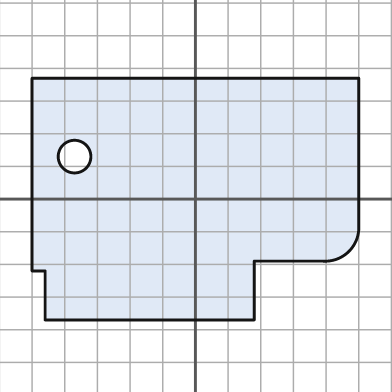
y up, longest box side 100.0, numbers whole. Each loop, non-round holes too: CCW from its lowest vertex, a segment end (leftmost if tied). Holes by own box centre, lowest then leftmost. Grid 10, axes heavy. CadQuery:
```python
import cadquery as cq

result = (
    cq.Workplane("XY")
    .moveTo(-46.0, -37.0)
    .lineTo(18.0, -37.0)
    .lineTo(18.0, -19.0)
    .lineTo(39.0, -19.0)
    .threePointArc((47.0, -16.0), (50.0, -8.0))
    .lineTo(50.0, 37.0)
    .lineTo(-50.0, 37.0)
    .lineTo(-50.0, -22.0)
    .lineTo(-46.0, -22.0)
    .close()
    .moveTo(-37.0, 13.0)
    .circle(5.0)
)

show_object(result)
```